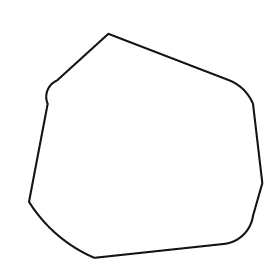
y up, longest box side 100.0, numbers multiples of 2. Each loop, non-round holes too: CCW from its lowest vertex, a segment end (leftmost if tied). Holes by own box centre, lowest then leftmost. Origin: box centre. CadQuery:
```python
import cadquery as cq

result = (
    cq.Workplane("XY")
    .moveTo(-22.0, -48.0)
    .lineTo(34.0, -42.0)
    .threePointArc((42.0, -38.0), (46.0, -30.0))
    .lineTo(50.0, -16.0)
    .lineTo(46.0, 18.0)
    .threePointArc((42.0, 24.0), (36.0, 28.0))
    .lineTo(-16.0, 48.0)
    .lineTo(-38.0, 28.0)
    .threePointArc((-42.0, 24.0), (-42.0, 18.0))
    .lineTo(-50.0, -24.0)
    .threePointArc((-38.0, -38.0), (-22.0, -48.0))
    .close()
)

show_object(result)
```